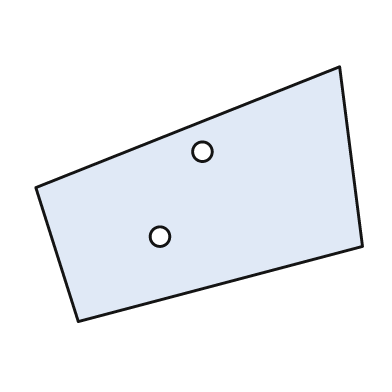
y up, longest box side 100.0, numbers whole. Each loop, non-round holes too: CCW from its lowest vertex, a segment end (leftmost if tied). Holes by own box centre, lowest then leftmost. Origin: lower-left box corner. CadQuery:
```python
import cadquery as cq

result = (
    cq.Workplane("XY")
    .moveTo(13.0, 0.0)
    .lineTo(100.0, 23.0)
    .lineTo(93.0, 78.0)
    .lineTo(0.0, 41.0)
    .close()
    .moveTo(38.0, 26.0)
    .circle(3.0)
    .moveTo(51.0, 52.0)
    .circle(3.0)
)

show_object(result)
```